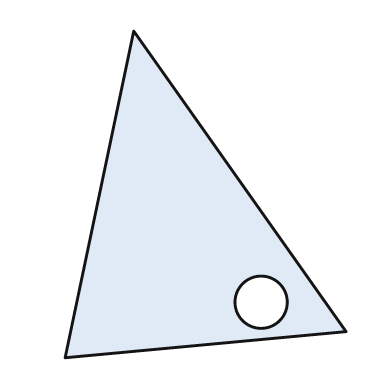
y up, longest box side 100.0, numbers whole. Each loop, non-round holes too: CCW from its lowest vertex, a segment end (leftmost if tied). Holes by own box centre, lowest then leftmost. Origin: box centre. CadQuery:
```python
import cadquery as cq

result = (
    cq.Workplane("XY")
    .moveTo(-43.0, -50.0)
    .lineTo(43.0, -42.0)
    .lineTo(-22.0, 50.0)
    .close()
    .moveTo(17.0, -33.0)
    .circle(8.0)
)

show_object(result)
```